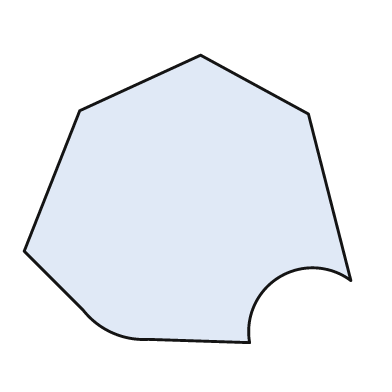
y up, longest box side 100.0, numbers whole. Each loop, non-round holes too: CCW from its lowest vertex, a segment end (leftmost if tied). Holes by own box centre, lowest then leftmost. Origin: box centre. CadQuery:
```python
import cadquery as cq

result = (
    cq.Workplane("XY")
    .moveTo(19.0, -44.0)
    .threePointArc((28.0, -24.0), (50.0, -25.0))
    .lineTo(37.0, 26.0)
    .lineTo(4.0, 44.0)
    .lineTo(-33.0, 27.0)
    .lineTo(-50.0, -16.0)
    .lineTo(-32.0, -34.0)
    .threePointArc((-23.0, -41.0), (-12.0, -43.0))
    .close()
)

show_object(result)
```